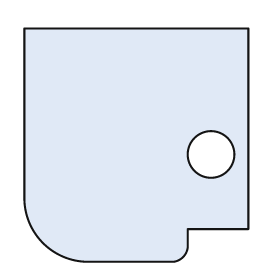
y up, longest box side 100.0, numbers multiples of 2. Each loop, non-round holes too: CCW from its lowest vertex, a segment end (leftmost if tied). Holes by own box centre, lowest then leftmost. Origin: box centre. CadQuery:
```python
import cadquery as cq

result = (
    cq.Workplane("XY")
    .moveTo(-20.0, -50.0)
    .lineTo(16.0, -50.0)
    .threePointArc((20.0, -48.0), (22.0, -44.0))
    .lineTo(22.0, -36.0)
    .lineTo(48.0, -36.0)
    .lineTo(48.0, 50.0)
    .lineTo(-48.0, 50.0)
    .lineTo(-48.0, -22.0)
    .threePointArc((-40.0, -42.0), (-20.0, -50.0))
    .close()
    .moveTo(32.0, -4.0)
    .circle(10.0)
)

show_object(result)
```